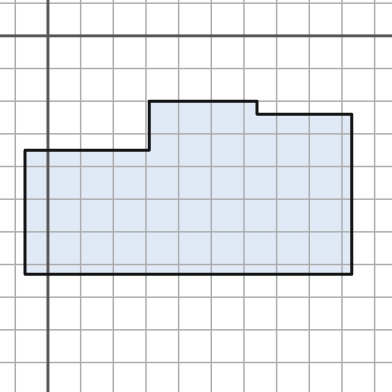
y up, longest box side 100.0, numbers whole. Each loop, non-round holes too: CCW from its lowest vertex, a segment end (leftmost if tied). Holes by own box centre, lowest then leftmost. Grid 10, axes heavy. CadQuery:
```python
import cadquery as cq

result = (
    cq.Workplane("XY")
    .moveTo(-7.0, -73.0)
    .lineTo(93.0, -73.0)
    .lineTo(93.0, -24.0)
    .lineTo(64.0, -24.0)
    .lineTo(64.0, -20.0)
    .lineTo(31.0, -20.0)
    .lineTo(31.0, -35.0)
    .lineTo(-7.0, -35.0)
    .close()
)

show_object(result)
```